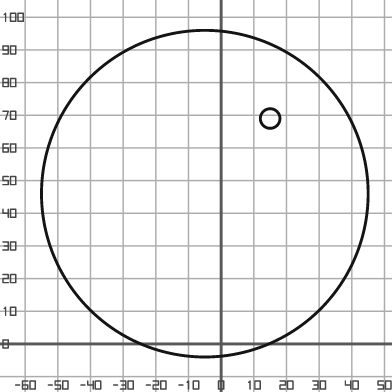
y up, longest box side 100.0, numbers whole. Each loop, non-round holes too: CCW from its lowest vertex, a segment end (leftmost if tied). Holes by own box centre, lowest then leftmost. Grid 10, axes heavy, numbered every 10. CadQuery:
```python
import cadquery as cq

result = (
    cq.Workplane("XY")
    .moveTo(-5.0, 46.0)
    .circle(50.0)
    .moveTo(15.0, 69.0)
    .circle(3.0)
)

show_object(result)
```